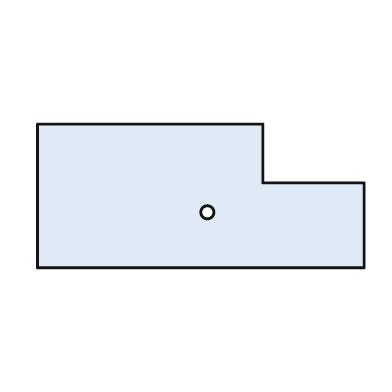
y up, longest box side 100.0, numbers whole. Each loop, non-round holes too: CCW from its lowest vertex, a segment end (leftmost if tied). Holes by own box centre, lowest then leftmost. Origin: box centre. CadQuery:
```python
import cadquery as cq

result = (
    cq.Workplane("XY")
    .moveTo(-50.0, -22.0)
    .lineTo(50.0, -22.0)
    .lineTo(50.0, 4.0)
    .lineTo(19.0, 4.0)
    .lineTo(19.0, 22.0)
    .lineTo(-50.0, 22.0)
    .close()
    .moveTo(2.0, -5.0)
    .circle(2.0)
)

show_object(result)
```